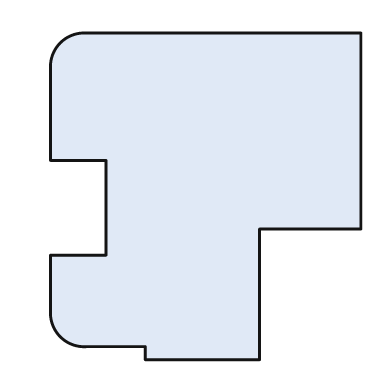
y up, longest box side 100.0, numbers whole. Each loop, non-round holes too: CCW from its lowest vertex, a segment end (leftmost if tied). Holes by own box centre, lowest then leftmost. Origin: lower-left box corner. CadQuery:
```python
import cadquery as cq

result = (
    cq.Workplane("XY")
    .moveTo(29.0, 0.0)
    .lineTo(64.0, 0.0)
    .lineTo(64.0, 40.0)
    .lineTo(95.0, 40.0)
    .lineTo(95.0, 100.0)
    .lineTo(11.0, 100.0)
    .threePointArc((3.0, 97.0), (0.0, 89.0))
    .lineTo(0.0, 61.0)
    .lineTo(17.0, 61.0)
    .lineTo(17.0, 32.0)
    .lineTo(0.0, 32.0)
    .lineTo(0.0, 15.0)
    .threePointArc((3.0, 7.0), (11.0, 4.0))
    .lineTo(29.0, 4.0)
    .close()
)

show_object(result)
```